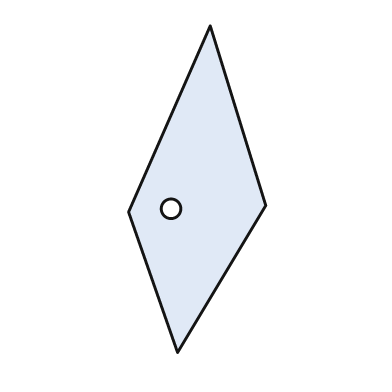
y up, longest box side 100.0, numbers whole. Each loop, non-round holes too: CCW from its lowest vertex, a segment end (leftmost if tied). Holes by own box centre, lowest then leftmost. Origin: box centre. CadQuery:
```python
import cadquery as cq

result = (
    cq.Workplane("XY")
    .moveTo(-6.0, -50.0)
    .lineTo(21.0, -5.0)
    .lineTo(4.0, 50.0)
    .lineTo(-21.0, -7.0)
    .close()
    .moveTo(-8.0, -6.0)
    .circle(3.0)
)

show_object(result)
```